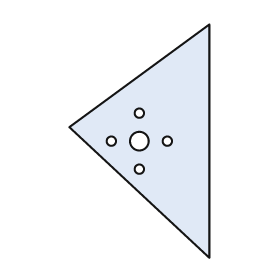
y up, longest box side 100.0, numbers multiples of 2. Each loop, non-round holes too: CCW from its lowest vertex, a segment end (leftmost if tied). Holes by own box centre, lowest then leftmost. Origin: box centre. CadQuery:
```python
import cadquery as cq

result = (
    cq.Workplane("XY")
    .moveTo(30.0, -50.0)
    .lineTo(30.0, 50.0)
    .lineTo(-30.0, 6.0)
    .close()
    .moveTo(0.0, -12.0)
    .circle(2.0)
    .moveTo(-12.0, 0.0)
    .circle(2.0)
    .moveTo(0.0, 0.0)
    .circle(4.0)
    .moveTo(12.0, 0.0)
    .circle(2.0)
    .moveTo(0.0, 12.0)
    .circle(2.0)
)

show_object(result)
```